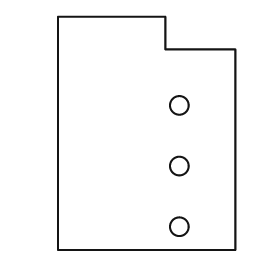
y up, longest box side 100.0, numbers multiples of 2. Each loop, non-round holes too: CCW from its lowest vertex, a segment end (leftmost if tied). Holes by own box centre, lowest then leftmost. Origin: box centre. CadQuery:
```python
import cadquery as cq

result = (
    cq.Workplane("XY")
    .moveTo(-38.0, -50.0)
    .lineTo(38.0, -50.0)
    .lineTo(38.0, 36.0)
    .lineTo(8.0, 36.0)
    .lineTo(8.0, 50.0)
    .lineTo(-38.0, 50.0)
    .close()
    .moveTo(14.0, -40.0)
    .circle(4.0)
    .moveTo(14.0, -14.0)
    .circle(4.0)
    .moveTo(14.0, 12.0)
    .circle(4.0)
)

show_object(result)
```